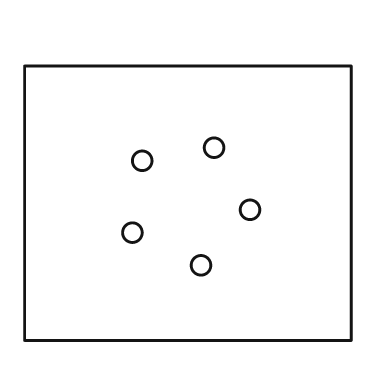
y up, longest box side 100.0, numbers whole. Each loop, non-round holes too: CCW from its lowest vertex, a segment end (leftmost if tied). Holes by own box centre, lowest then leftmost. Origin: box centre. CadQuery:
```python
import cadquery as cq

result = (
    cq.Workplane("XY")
    .moveTo(-50.0, -42.0)
    .lineTo(50.0, -42.0)
    .lineTo(50.0, 42.0)
    .lineTo(-50.0, 42.0)
    .close()
    .moveTo(4.0, -19.0)
    .circle(3.0)
    .moveTo(-17.0, -9.0)
    .circle(3.0)
    .moveTo(19.0, -2.0)
    .circle(3.0)
    .moveTo(-14.0, 13.0)
    .circle(3.0)
    .moveTo(8.0, 17.0)
    .circle(3.0)
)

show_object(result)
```